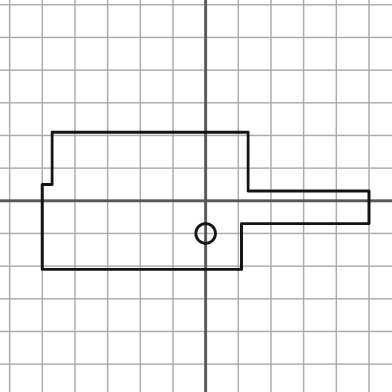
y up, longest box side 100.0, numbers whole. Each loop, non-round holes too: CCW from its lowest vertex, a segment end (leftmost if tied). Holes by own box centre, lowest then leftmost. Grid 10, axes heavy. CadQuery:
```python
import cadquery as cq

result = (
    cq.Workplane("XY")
    .moveTo(-50.0, -21.0)
    .lineTo(11.0, -21.0)
    .lineTo(11.0, -7.0)
    .lineTo(50.0, -7.0)
    .lineTo(50.0, 3.0)
    .lineTo(13.0, 3.0)
    .lineTo(13.0, 21.0)
    .lineTo(-47.0, 21.0)
    .lineTo(-47.0, 5.0)
    .lineTo(-50.0, 5.0)
    .close()
    .moveTo(0.0, -10.0)
    .circle(3.0)
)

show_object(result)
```